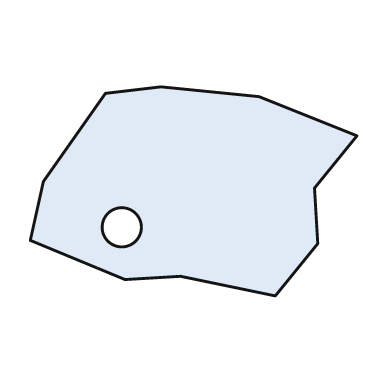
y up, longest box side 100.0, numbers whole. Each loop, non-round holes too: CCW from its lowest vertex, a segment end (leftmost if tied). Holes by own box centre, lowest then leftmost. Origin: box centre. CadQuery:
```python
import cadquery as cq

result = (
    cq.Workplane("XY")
    .moveTo(25.0, -32.0)
    .lineTo(38.0, -16.0)
    .lineTo(37.0, 1.0)
    .lineTo(50.0, 17.0)
    .lineTo(20.0, 29.0)
    .lineTo(-10.0, 32.0)
    .lineTo(-27.0, 30.0)
    .lineTo(-46.0, 3.0)
    .lineTo(-50.0, -15.0)
    .lineTo(-21.0, -27.0)
    .lineTo(-4.0, -26.0)
    .close()
    .moveTo(-22.0, -11.0)
    .circle(6.0)
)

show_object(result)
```